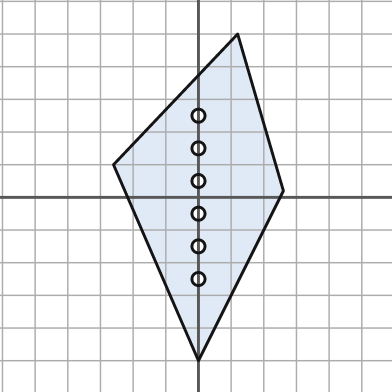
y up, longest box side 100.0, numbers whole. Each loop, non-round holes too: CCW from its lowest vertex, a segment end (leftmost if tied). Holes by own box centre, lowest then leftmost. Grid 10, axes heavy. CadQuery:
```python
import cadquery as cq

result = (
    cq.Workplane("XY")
    .moveTo(0.0, -50.0)
    .lineTo(26.0, 2.0)
    .lineTo(12.0, 50.0)
    .lineTo(-26.0, 10.0)
    .close()
    .moveTo(0.0, -25.0)
    .circle(2.0)
    .moveTo(0.0, -15.0)
    .circle(2.0)
    .moveTo(0.0, -5.0)
    .circle(2.0)
    .moveTo(0.0, 5.0)
    .circle(2.0)
    .moveTo(0.0, 15.0)
    .circle(2.0)
    .moveTo(0.0, 25.0)
    .circle(2.0)
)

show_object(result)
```